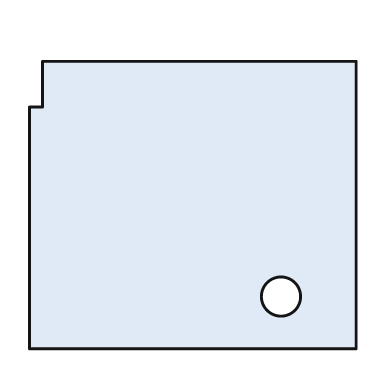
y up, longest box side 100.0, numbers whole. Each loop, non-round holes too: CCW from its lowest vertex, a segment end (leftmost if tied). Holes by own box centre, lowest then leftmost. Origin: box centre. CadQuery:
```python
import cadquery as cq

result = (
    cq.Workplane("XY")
    .moveTo(-50.0, -44.0)
    .lineTo(50.0, -44.0)
    .lineTo(50.0, 44.0)
    .lineTo(-46.0, 44.0)
    .lineTo(-46.0, 30.0)
    .lineTo(-50.0, 30.0)
    .close()
    .moveTo(27.0, -28.0)
    .circle(6.0)
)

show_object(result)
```